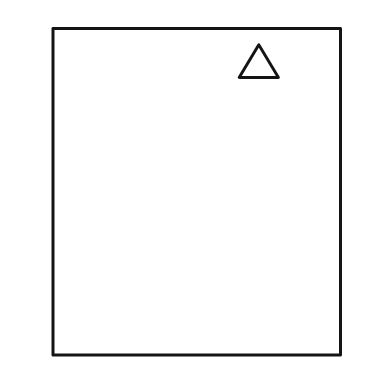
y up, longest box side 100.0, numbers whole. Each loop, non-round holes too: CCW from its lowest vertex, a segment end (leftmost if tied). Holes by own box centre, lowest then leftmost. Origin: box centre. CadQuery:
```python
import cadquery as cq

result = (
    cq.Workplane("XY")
    .moveTo(-44.0, -50.0)
    .lineTo(44.0, -50.0)
    .lineTo(44.0, 50.0)
    .lineTo(-44.0, 50.0)
    .close()
    .moveTo(13.0, 35.0)
    .lineTo(25.0, 35.0)
    .lineTo(19.0, 45.0)
    .close()
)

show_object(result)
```